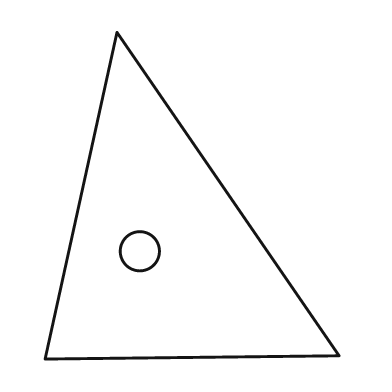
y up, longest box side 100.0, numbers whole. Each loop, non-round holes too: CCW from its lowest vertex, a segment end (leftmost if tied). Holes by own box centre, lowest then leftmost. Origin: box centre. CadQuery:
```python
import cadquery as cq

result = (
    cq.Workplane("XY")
    .moveTo(-45.0, -50.0)
    .lineTo(45.0, -49.0)
    .lineTo(-23.0, 50.0)
    .close()
    .moveTo(-16.0, -17.0)
    .circle(6.0)
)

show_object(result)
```